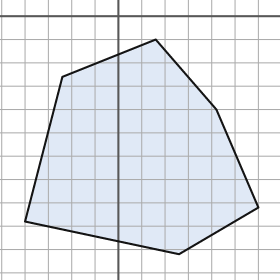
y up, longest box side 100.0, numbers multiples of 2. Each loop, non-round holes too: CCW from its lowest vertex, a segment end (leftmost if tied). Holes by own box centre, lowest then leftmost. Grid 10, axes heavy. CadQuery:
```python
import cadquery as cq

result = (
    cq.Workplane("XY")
    .moveTo(26.0, -102.0)
    .lineTo(60.0, -82.0)
    .lineTo(42.0, -40.0)
    .lineTo(16.0, -10.0)
    .lineTo(-24.0, -26.0)
    .lineTo(-40.0, -88.0)
    .close()
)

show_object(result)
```